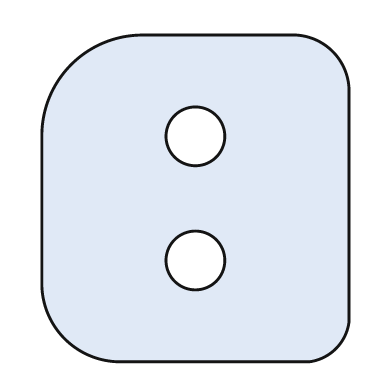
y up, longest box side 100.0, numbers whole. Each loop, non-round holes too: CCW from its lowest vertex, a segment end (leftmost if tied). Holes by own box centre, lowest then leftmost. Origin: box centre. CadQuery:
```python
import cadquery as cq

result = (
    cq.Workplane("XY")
    .moveTo(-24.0, -50.0)
    .lineTo(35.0, -50.0)
    .threePointArc((43.0, -46.0), (47.0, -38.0))
    .lineTo(47.0, 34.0)
    .threePointArc((42.0, 45.0), (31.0, 50.0))
    .lineTo(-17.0, 50.0)
    .threePointArc((-38.0, 41.0), (-47.0, 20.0))
    .lineTo(-47.0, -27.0)
    .threePointArc((-40.0, -43.0), (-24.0, -50.0))
    .close()
    .moveTo(0.0, -19.0)
    .circle(9.0)
    .moveTo(0.0, 19.0)
    .circle(9.0)
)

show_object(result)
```